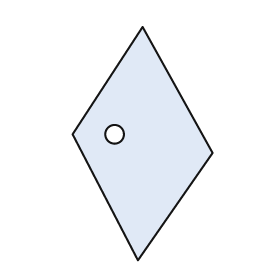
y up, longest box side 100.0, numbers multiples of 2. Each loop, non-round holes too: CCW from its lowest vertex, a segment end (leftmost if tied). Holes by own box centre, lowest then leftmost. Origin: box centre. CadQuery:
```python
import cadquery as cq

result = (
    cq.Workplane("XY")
    .moveTo(-2.0, -50.0)
    .lineTo(30.0, -4.0)
    .lineTo(0.0, 50.0)
    .lineTo(-30.0, 4.0)
    .close()
    .moveTo(-12.0, 4.0)
    .circle(4.0)
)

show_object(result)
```